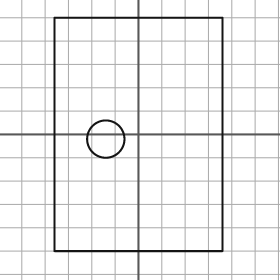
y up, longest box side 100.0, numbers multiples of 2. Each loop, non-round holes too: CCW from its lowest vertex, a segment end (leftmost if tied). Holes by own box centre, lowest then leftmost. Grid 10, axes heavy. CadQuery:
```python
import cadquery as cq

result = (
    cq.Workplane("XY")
    .moveTo(-36.0, -50.0)
    .lineTo(36.0, -50.0)
    .lineTo(36.0, 50.0)
    .lineTo(-36.0, 50.0)
    .close()
    .moveTo(-14.0, -2.0)
    .circle(8.0)
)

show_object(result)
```